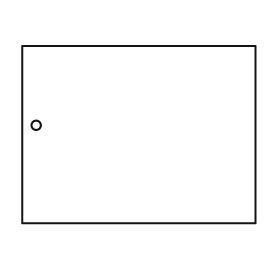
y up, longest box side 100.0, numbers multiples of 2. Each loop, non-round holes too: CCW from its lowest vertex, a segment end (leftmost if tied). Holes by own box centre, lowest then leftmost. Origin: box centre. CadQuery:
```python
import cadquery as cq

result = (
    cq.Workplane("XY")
    .moveTo(-50.0, -38.0)
    .lineTo(50.0, -38.0)
    .lineTo(50.0, 38.0)
    .lineTo(-50.0, 38.0)
    .close()
    .moveTo(-44.0, 4.0)
    .circle(2.0)
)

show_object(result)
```